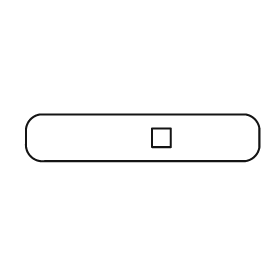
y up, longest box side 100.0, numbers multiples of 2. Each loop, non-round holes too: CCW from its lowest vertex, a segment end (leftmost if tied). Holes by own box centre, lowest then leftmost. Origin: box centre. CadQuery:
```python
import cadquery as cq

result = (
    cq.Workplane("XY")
    .moveTo(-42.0, -10.0)
    .lineTo(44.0, -10.0)
    .threePointArc((48.0, -8.0), (50.0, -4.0))
    .lineTo(50.0, 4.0)
    .threePointArc((48.0, 8.0), (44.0, 10.0))
    .lineTo(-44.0, 10.0)
    .threePointArc((-48.0, 8.0), (-50.0, 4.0))
    .lineTo(-50.0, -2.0)
    .threePointArc((-48.0, -8.0), (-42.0, -10.0))
    .close()
    .moveTo(4.0, -4.0)
    .lineTo(12.0, -4.0)
    .lineTo(12.0, 4.0)
    .lineTo(4.0, 4.0)
    .close()
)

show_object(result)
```